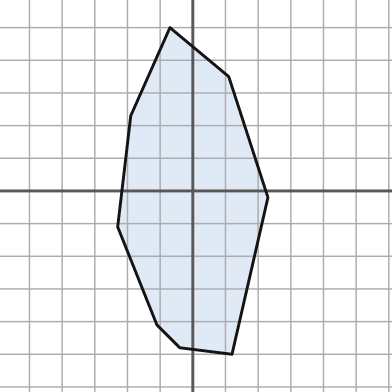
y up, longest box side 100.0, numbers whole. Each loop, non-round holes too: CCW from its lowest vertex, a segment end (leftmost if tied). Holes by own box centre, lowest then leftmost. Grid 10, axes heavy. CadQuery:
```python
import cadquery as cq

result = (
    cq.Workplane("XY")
    .moveTo(12.0, -50.0)
    .lineTo(23.0, -2.0)
    .lineTo(11.0, 35.0)
    .lineTo(-7.0, 50.0)
    .lineTo(-19.0, 23.0)
    .lineTo(-23.0, -11.0)
    .lineTo(-11.0, -41.0)
    .lineTo(-4.0, -48.0)
    .close()
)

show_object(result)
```